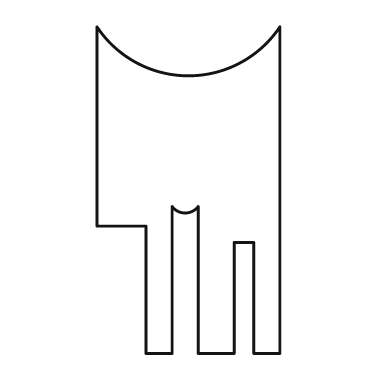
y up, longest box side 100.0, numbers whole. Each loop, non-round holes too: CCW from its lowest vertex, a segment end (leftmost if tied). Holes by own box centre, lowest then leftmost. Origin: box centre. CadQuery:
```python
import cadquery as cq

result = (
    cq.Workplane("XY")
    .moveTo(-13.0, -50.0)
    .lineTo(-5.0, -50.0)
    .lineTo(-5.0, -5.0)
    .threePointArc((-1.0, -7.0), (3.0, -5.0))
    .lineTo(3.0, -50.0)
    .lineTo(14.0, -50.0)
    .lineTo(14.0, -16.0)
    .lineTo(20.0, -16.0)
    .lineTo(20.0, -50.0)
    .lineTo(28.0, -50.0)
    .lineTo(28.0, 50.0)
    .threePointArc((0.0, 35.0), (-28.0, 50.0))
    .lineTo(-28.0, -11.0)
    .lineTo(-13.0, -11.0)
    .close()
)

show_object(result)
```